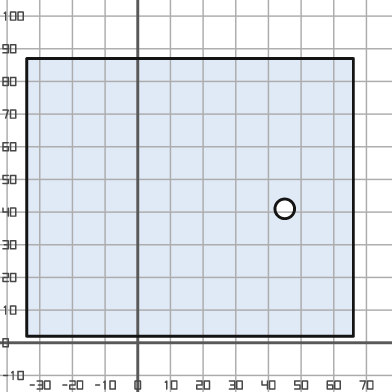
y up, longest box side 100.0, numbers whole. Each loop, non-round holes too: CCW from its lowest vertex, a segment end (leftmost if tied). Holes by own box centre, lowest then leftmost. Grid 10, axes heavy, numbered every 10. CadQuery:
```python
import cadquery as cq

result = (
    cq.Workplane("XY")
    .moveTo(-34.0, 2.0)
    .lineTo(66.0, 2.0)
    .lineTo(66.0, 87.0)
    .lineTo(-34.0, 87.0)
    .close()
    .moveTo(45.0, 41.0)
    .circle(3.0)
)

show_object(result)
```